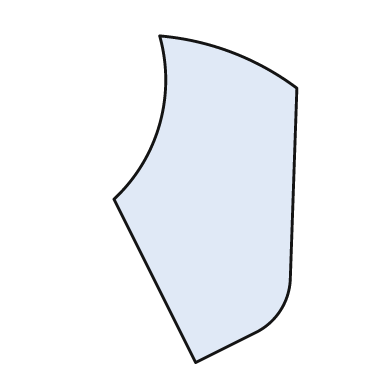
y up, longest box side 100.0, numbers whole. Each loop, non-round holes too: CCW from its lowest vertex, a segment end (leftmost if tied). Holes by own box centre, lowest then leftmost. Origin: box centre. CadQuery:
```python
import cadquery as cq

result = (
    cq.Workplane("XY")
    .moveTo(-3.0, -50.0)
    .lineTo(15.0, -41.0)
    .threePointArc((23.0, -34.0), (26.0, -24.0))
    .lineTo(28.0, 34.0)
    .threePointArc((8.0, 45.0), (-14.0, 50.0))
    .threePointArc((-14.0, 23.0), (-28.0, 0.0))
    .close()
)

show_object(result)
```